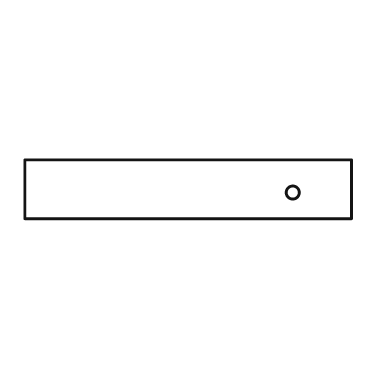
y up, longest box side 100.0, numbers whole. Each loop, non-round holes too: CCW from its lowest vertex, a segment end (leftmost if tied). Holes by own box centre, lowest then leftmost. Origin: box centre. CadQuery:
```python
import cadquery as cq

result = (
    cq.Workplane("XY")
    .moveTo(-50.0, -9.0)
    .lineTo(50.0, -9.0)
    .lineTo(50.0, 9.0)
    .lineTo(-50.0, 9.0)
    .close()
    .moveTo(32.0, -1.0)
    .circle(2.0)
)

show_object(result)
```